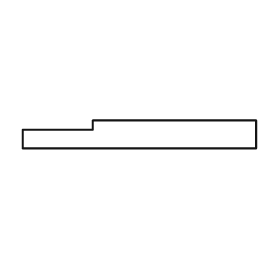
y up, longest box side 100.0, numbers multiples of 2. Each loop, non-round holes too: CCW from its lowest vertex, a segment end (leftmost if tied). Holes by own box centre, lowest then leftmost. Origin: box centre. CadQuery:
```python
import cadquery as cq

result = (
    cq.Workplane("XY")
    .moveTo(-50.0, -6.0)
    .lineTo(50.0, -6.0)
    .lineTo(50.0, 6.0)
    .lineTo(-20.0, 6.0)
    .lineTo(-20.0, 2.0)
    .lineTo(-50.0, 2.0)
    .close()
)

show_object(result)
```